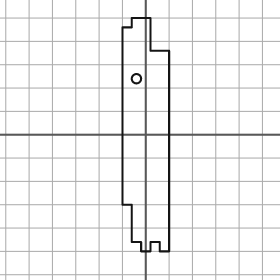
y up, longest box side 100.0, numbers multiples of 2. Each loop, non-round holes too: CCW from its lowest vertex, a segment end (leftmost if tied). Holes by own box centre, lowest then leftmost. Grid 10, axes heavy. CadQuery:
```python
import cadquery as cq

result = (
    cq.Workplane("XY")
    .moveTo(-2.0, -50.0)
    .lineTo(2.0, -50.0)
    .lineTo(2.0, -46.0)
    .lineTo(6.0, -46.0)
    .lineTo(6.0, -50.0)
    .lineTo(10.0, -50.0)
    .lineTo(10.0, 36.0)
    .lineTo(2.0, 36.0)
    .lineTo(2.0, 50.0)
    .lineTo(-6.0, 50.0)
    .lineTo(-6.0, 46.0)
    .lineTo(-10.0, 46.0)
    .lineTo(-10.0, -30.0)
    .lineTo(-6.0, -30.0)
    .lineTo(-6.0, -46.0)
    .lineTo(-2.0, -46.0)
    .close()
    .moveTo(-4.0, 24.0)
    .circle(2.0)
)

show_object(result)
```